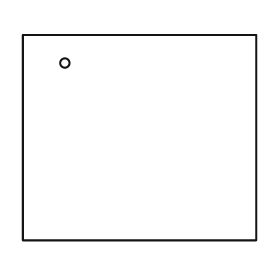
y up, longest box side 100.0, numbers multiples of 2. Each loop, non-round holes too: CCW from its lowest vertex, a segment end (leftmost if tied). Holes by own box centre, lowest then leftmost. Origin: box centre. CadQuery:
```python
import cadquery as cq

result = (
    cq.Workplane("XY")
    .moveTo(-50.0, -44.0)
    .lineTo(50.0, -44.0)
    .lineTo(50.0, 44.0)
    .lineTo(-50.0, 44.0)
    .close()
    .moveTo(-32.0, 32.0)
    .circle(2.0)
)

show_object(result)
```